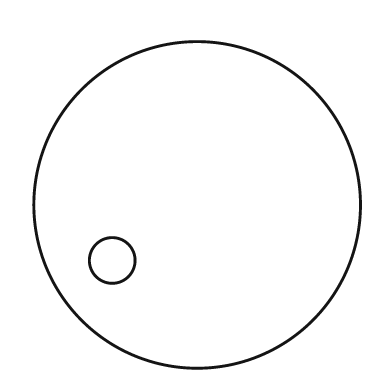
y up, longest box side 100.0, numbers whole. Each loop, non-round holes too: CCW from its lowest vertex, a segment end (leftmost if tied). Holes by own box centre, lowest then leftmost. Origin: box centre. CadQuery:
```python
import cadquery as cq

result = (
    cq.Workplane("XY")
    .moveTo(0.0, 0.0)
    .circle(50.0)
    .moveTo(-26.0, -17.0)
    .circle(7.0)
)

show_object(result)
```